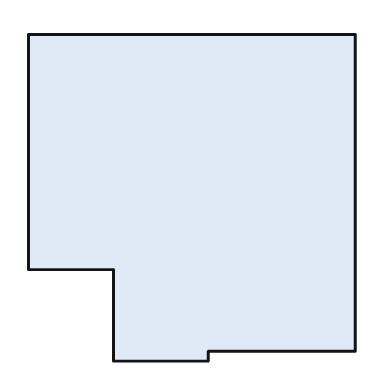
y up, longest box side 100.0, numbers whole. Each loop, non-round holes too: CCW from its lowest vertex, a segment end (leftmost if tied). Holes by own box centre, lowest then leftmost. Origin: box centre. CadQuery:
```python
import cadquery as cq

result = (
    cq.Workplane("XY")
    .moveTo(-24.0, -50.0)
    .lineTo(5.0, -50.0)
    .lineTo(5.0, -47.0)
    .lineTo(50.0, -47.0)
    .lineTo(50.0, 50.0)
    .lineTo(-50.0, 50.0)
    .lineTo(-50.0, -22.0)
    .lineTo(-24.0, -22.0)
    .close()
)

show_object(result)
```